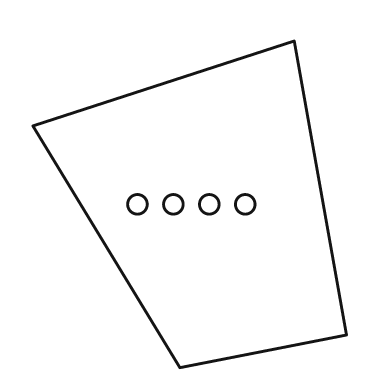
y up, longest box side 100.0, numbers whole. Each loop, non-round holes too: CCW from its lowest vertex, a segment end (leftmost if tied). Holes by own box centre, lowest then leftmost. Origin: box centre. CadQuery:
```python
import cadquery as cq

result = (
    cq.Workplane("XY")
    .moveTo(-3.0, -50.0)
    .lineTo(48.0, -40.0)
    .lineTo(32.0, 50.0)
    .lineTo(-48.0, 24.0)
    .close()
    .moveTo(-16.0, 0.0)
    .circle(3.0)
    .moveTo(-5.0, 0.0)
    .circle(3.0)
    .moveTo(6.0, 0.0)
    .circle(3.0)
    .moveTo(17.0, 0.0)
    .circle(3.0)
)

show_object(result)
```